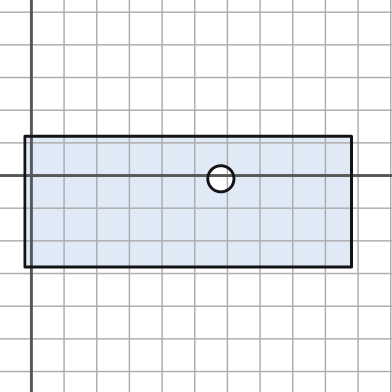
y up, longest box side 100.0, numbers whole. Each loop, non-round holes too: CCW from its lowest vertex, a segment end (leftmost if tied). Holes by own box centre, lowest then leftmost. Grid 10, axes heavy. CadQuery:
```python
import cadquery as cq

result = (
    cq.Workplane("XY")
    .moveTo(-2.0, -28.0)
    .lineTo(98.0, -28.0)
    .lineTo(98.0, 12.0)
    .lineTo(-2.0, 12.0)
    .close()
    .moveTo(58.0, -1.0)
    .circle(4.0)
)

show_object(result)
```